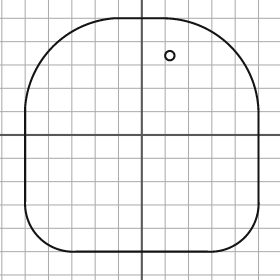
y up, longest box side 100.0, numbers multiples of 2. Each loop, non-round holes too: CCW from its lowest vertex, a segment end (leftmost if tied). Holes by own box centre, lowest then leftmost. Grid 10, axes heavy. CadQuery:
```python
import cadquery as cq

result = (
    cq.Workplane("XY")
    .moveTo(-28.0, -50.0)
    .lineTo(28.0, -50.0)
    .threePointArc((44.0, -44.0), (50.0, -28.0))
    .lineTo(50.0, 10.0)
    .threePointArc((38.0, 38.0), (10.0, 50.0))
    .lineTo(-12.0, 50.0)
    .threePointArc((-38.0, 38.0), (-50.0, 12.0))
    .lineTo(-50.0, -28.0)
    .threePointArc((-44.0, -44.0), (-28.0, -50.0))
    .close()
    .moveTo(12.0, 34.0)
    .circle(2.0)
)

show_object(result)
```